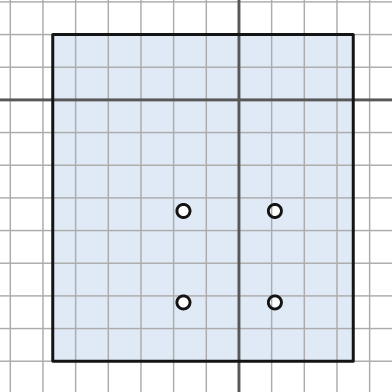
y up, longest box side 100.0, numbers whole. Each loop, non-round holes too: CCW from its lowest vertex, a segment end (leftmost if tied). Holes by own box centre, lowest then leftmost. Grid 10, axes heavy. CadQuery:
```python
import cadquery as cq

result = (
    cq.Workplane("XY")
    .moveTo(-57.0, -80.0)
    .lineTo(35.0, -80.0)
    .lineTo(35.0, 20.0)
    .lineTo(-57.0, 20.0)
    .close()
    .moveTo(-17.0, -62.0)
    .circle(2.0)
    .moveTo(11.0, -62.0)
    .circle(2.0)
    .moveTo(-17.0, -34.0)
    .circle(2.0)
    .moveTo(11.0, -34.0)
    .circle(2.0)
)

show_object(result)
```